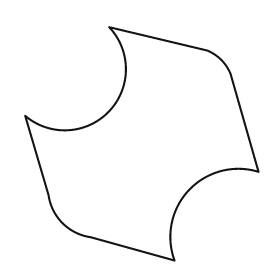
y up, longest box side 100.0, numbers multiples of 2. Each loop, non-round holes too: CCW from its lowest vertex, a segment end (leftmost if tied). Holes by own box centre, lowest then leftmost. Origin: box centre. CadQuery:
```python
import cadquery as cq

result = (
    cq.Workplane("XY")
    .moveTo(14.0, -50.0)
    .threePointArc((20.0, -20.0), (50.0, -12.0))
    .lineTo(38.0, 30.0)
    .threePointArc((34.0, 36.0), (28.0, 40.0))
    .lineTo(-14.0, 50.0)
    .threePointArc((-14.0, 14.0), (-50.0, 12.0))
    .lineTo(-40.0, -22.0)
    .threePointArc((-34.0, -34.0), (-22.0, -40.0))
    .close()
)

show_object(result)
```